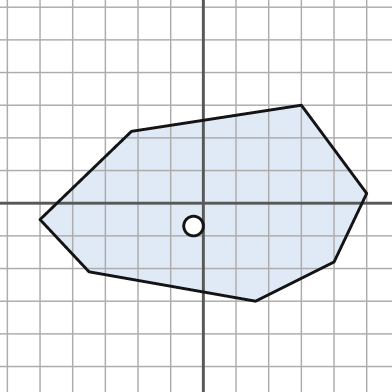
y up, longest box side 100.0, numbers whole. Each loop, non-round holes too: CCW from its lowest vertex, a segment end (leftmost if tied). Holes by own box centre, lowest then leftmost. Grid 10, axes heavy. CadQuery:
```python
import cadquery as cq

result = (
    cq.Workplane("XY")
    .moveTo(16.0, -30.0)
    .lineTo(40.0, -18.0)
    .lineTo(50.0, 3.0)
    .lineTo(30.0, 30.0)
    .lineTo(-22.0, 22.0)
    .lineTo(-50.0, -5.0)
    .lineTo(-35.0, -21.0)
    .close()
    .moveTo(-3.0, -7.0)
    .circle(3.0)
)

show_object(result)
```